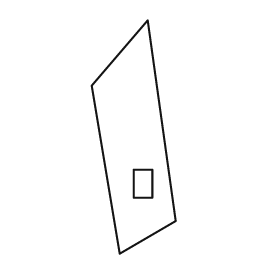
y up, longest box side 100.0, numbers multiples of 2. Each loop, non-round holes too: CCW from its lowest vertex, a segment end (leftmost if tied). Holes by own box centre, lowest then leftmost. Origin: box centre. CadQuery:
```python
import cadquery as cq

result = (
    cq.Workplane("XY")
    .moveTo(-6.0, -50.0)
    .lineTo(18.0, -36.0)
    .lineTo(6.0, 50.0)
    .lineTo(-18.0, 22.0)
    .close()
    .moveTo(0.0, -26.0)
    .lineTo(8.0, -26.0)
    .lineTo(8.0, -14.0)
    .lineTo(0.0, -14.0)
    .close()
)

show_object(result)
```